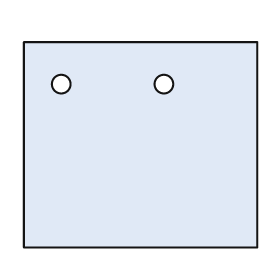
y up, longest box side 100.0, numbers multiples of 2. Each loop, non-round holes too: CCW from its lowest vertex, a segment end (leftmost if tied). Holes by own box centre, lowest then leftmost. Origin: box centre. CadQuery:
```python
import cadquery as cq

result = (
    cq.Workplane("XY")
    .moveTo(-50.0, -44.0)
    .lineTo(50.0, -44.0)
    .lineTo(50.0, 44.0)
    .lineTo(-50.0, 44.0)
    .close()
    .moveTo(-34.0, 26.0)
    .circle(4.0)
    .moveTo(10.0, 26.0)
    .circle(4.0)
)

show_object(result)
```